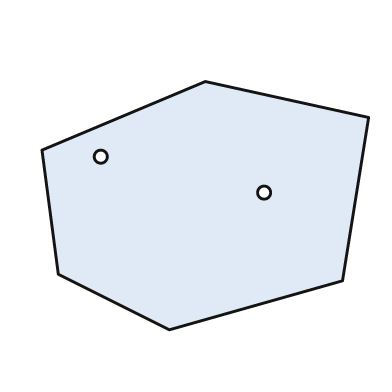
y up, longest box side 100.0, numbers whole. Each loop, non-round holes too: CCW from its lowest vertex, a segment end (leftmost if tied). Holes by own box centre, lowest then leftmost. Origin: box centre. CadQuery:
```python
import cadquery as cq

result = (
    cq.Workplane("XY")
    .moveTo(-11.0, -38.0)
    .lineTo(42.0, -23.0)
    .lineTo(50.0, 27.0)
    .lineTo(0.0, 38.0)
    .lineTo(-50.0, 17.0)
    .lineTo(-45.0, -21.0)
    .close()
    .moveTo(18.0, 4.0)
    .circle(2.0)
    .moveTo(-32.0, 15.0)
    .circle(2.0)
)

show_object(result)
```